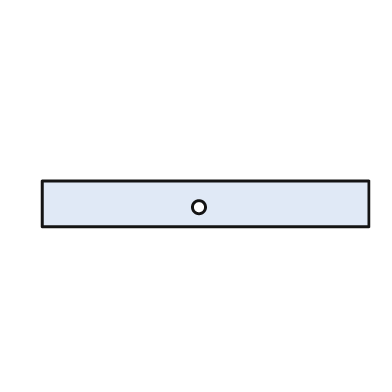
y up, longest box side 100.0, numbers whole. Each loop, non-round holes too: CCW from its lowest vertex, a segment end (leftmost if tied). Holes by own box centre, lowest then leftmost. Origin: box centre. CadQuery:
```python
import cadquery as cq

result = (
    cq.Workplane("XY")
    .moveTo(-50.0, -7.0)
    .lineTo(50.0, -7.0)
    .lineTo(50.0, 7.0)
    .lineTo(-50.0, 7.0)
    .close()
    .moveTo(-2.0, -1.0)
    .circle(2.0)
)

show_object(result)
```